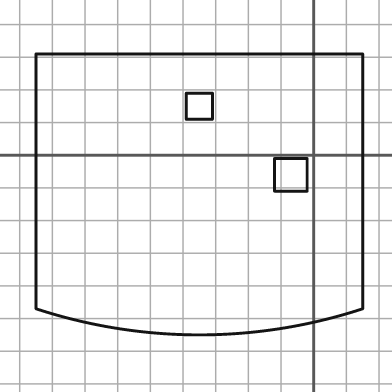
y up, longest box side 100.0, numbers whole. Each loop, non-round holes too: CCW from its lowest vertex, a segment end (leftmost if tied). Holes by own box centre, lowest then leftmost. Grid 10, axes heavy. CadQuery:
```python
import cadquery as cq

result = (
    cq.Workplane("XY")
    .moveTo(-85.0, -47.0)
    .threePointArc((-35.0, -55.0), (15.0, -47.0))
    .lineTo(15.0, 31.0)
    .lineTo(-85.0, 31.0)
    .close()
    .moveTo(-12.0, -11.0)
    .lineTo(-2.0, -11.0)
    .lineTo(-2.0, -1.0)
    .lineTo(-12.0, -1.0)
    .close()
    .moveTo(-39.0, 11.0)
    .lineTo(-31.0, 11.0)
    .lineTo(-31.0, 19.0)
    .lineTo(-39.0, 19.0)
    .close()
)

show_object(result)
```